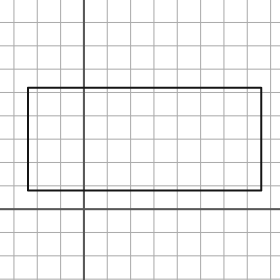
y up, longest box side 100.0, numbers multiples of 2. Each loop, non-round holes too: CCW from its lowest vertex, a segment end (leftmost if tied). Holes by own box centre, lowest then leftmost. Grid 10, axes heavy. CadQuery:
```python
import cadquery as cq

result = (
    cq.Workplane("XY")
    .moveTo(-24.0, 8.0)
    .lineTo(76.0, 8.0)
    .lineTo(76.0, 52.0)
    .lineTo(-24.0, 52.0)
    .close()
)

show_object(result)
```